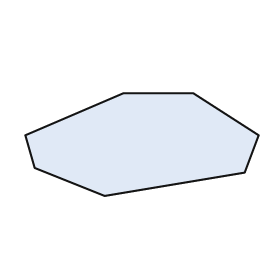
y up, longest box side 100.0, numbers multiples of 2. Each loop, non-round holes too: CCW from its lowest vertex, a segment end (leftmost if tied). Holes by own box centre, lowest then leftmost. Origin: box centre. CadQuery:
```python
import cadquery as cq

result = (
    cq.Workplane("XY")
    .moveTo(-16.0, -22.0)
    .lineTo(44.0, -12.0)
    .lineTo(50.0, 4.0)
    .lineTo(22.0, 22.0)
    .lineTo(-8.0, 22.0)
    .lineTo(-50.0, 4.0)
    .lineTo(-46.0, -10.0)
    .close()
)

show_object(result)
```